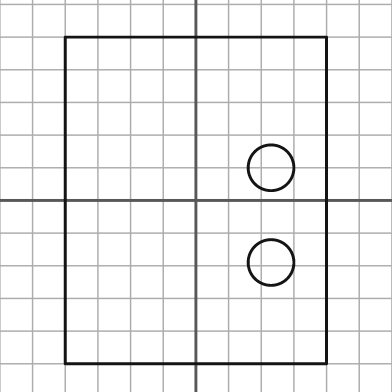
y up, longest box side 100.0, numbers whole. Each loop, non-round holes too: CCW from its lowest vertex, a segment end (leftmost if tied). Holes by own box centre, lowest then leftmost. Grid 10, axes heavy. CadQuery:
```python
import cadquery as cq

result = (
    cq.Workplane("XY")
    .moveTo(-40.0, -50.0)
    .lineTo(40.0, -50.0)
    .lineTo(40.0, 50.0)
    .lineTo(-40.0, 50.0)
    .close()
    .moveTo(23.0, -19.0)
    .circle(7.0)
    .moveTo(23.0, 10.0)
    .circle(7.0)
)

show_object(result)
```